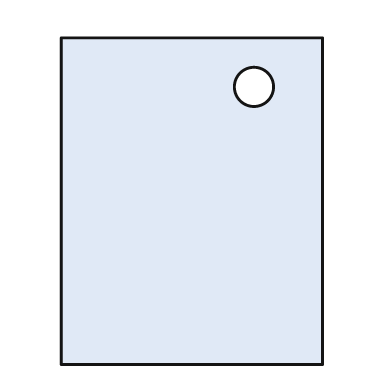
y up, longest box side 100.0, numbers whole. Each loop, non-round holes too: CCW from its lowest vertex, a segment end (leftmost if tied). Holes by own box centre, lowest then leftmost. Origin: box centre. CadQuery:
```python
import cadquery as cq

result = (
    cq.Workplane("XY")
    .moveTo(-40.0, -50.0)
    .lineTo(40.0, -50.0)
    .lineTo(40.0, 50.0)
    .lineTo(-40.0, 50.0)
    .close()
    .moveTo(19.0, 35.0)
    .circle(6.0)
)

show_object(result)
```